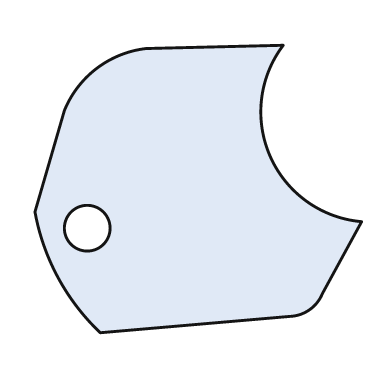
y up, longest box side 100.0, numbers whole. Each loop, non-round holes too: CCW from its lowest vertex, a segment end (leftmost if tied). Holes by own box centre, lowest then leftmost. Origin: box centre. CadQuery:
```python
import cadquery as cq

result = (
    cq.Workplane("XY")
    .moveTo(-30.0, -44.0)
    .lineTo(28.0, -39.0)
    .threePointArc((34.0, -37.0), (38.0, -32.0))
    .lineTo(50.0, -10.0)
    .threePointArc((22.0, 10.0), (26.0, 44.0))
    .lineTo(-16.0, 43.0)
    .threePointArc((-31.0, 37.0), (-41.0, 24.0))
    .lineTo(-50.0, -7.0)
    .threePointArc((-43.0, -27.0), (-30.0, -44.0))
    .close()
    .moveTo(-34.0, -12.0)
    .circle(7.0)
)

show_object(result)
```